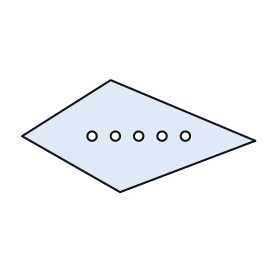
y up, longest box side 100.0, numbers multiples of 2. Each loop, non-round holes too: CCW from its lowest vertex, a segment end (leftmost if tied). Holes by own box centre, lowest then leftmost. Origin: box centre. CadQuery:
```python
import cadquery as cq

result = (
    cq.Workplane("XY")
    .moveTo(-8.0, -24.0)
    .lineTo(50.0, -2.0)
    .lineTo(-12.0, 24.0)
    .lineTo(-50.0, 0.0)
    .close()
    .moveTo(-20.0, 0.0)
    .circle(2.0)
    .moveTo(-10.0, 0.0)
    .circle(2.0)
    .moveTo(0.0, 0.0)
    .circle(2.0)
    .moveTo(10.0, 0.0)
    .circle(2.0)
    .moveTo(20.0, 0.0)
    .circle(2.0)
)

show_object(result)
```